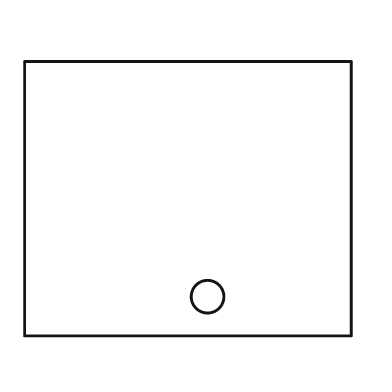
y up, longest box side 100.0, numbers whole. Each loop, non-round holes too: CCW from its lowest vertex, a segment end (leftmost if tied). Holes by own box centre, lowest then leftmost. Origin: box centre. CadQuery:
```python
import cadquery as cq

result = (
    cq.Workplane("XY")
    .moveTo(-50.0, -42.0)
    .lineTo(50.0, -42.0)
    .lineTo(50.0, 42.0)
    .lineTo(-50.0, 42.0)
    .close()
    .moveTo(6.0, -30.0)
    .circle(5.0)
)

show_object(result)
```